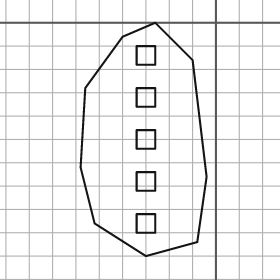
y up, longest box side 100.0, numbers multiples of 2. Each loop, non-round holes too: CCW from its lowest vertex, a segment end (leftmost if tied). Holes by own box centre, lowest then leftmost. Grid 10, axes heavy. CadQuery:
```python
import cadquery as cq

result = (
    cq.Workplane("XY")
    .moveTo(-30.0, -100.0)
    .lineTo(-8.0, -94.0)
    .lineTo(-4.0, -66.0)
    .lineTo(-10.0, -16.0)
    .lineTo(-26.0, 0.0)
    .lineTo(-40.0, -6.0)
    .lineTo(-56.0, -28.0)
    .lineTo(-58.0, -62.0)
    .lineTo(-52.0, -86.0)
    .close()
    .moveTo(-34.0, -90.0)
    .lineTo(-26.0, -90.0)
    .lineTo(-26.0, -82.0)
    .lineTo(-34.0, -82.0)
    .close()
    .moveTo(-34.0, -72.0)
    .lineTo(-26.0, -72.0)
    .lineTo(-26.0, -64.0)
    .lineTo(-34.0, -64.0)
    .close()
    .moveTo(-34.0, -54.0)
    .lineTo(-26.0, -54.0)
    .lineTo(-26.0, -46.0)
    .lineTo(-34.0, -46.0)
    .close()
    .moveTo(-34.0, -36.0)
    .lineTo(-26.0, -36.0)
    .lineTo(-26.0, -28.0)
    .lineTo(-34.0, -28.0)
    .close()
    .moveTo(-34.0, -18.0)
    .lineTo(-26.0, -18.0)
    .lineTo(-26.0, -10.0)
    .lineTo(-34.0, -10.0)
    .close()
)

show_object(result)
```